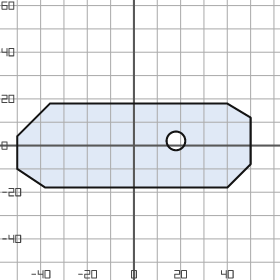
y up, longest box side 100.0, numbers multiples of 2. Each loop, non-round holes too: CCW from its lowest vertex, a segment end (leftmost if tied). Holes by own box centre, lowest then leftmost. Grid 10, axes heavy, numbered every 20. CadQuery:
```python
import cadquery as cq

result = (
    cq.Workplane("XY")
    .moveTo(-38.0, -18.0)
    .lineTo(40.0, -18.0)
    .lineTo(50.0, -8.0)
    .lineTo(50.0, 12.0)
    .lineTo(40.0, 18.0)
    .lineTo(-36.0, 18.0)
    .lineTo(-50.0, 4.0)
    .lineTo(-50.0, -10.0)
    .close()
    .moveTo(18.0, 2.0)
    .circle(4.0)
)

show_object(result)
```